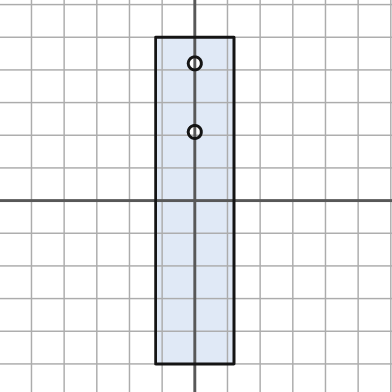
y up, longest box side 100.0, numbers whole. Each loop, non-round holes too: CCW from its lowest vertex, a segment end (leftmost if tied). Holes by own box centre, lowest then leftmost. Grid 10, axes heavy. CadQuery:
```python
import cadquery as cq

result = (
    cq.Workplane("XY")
    .moveTo(-12.0, -50.0)
    .lineTo(12.0, -50.0)
    .lineTo(12.0, 50.0)
    .lineTo(-12.0, 50.0)
    .close()
    .moveTo(0.0, 21.0)
    .circle(2.0)
    .moveTo(0.0, 42.0)
    .circle(2.0)
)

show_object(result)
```